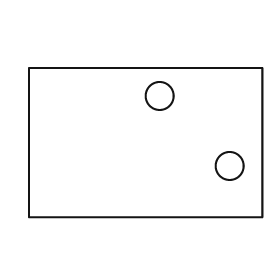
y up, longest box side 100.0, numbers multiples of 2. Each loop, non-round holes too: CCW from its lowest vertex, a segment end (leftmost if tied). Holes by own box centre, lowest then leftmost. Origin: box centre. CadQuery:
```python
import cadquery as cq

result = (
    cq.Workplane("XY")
    .moveTo(-50.0, -32.0)
    .lineTo(50.0, -32.0)
    .lineTo(50.0, 32.0)
    .lineTo(-50.0, 32.0)
    .close()
    .moveTo(36.0, -10.0)
    .circle(6.0)
    .moveTo(6.0, 20.0)
    .circle(6.0)
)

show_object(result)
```